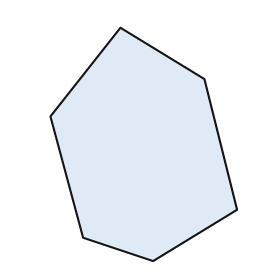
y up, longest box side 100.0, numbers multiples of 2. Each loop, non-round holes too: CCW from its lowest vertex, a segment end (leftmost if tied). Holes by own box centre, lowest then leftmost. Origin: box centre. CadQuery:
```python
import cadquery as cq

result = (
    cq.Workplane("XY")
    .moveTo(4.0, -50.0)
    .lineTo(40.0, -28.0)
    .lineTo(26.0, 28.0)
    .lineTo(-10.0, 50.0)
    .lineTo(-40.0, 12.0)
    .lineTo(-26.0, -40.0)
    .close()
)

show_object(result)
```